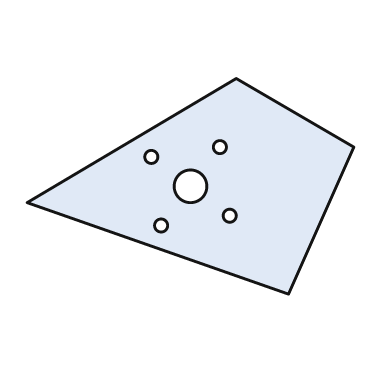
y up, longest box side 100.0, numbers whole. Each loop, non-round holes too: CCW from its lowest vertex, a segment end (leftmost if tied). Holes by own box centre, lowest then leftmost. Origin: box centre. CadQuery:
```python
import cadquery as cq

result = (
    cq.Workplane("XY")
    .moveTo(30.0, -33.0)
    .lineTo(50.0, 12.0)
    .lineTo(14.0, 33.0)
    .lineTo(-50.0, -5.0)
    .close()
    .moveTo(-9.0, -12.0)
    .circle(2.0)
    .moveTo(12.0, -9.0)
    .circle(2.0)
    .moveTo(0.0, 0.0)
    .circle(5.0)
    .moveTo(-12.0, 9.0)
    .circle(2.0)
    .moveTo(9.0, 12.0)
    .circle(2.0)
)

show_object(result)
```